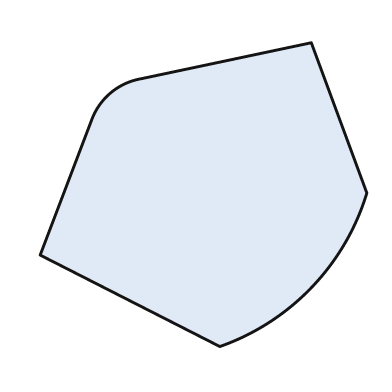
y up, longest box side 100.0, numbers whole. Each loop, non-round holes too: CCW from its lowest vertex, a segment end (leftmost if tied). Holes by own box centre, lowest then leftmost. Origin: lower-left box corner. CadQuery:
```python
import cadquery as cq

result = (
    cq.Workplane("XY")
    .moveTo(55.0, 0.0)
    .threePointArc((83.0, 18.0), (100.0, 47.0))
    .lineTo(83.0, 93.0)
    .lineTo(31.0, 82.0)
    .threePointArc((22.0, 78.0), (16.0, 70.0))
    .lineTo(0.0, 28.0)
    .close()
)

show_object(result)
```